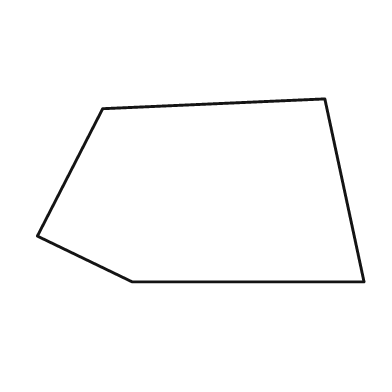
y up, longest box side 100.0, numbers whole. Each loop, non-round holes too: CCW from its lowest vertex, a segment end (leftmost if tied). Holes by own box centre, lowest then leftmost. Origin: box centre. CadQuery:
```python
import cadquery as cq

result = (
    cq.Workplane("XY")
    .moveTo(-21.0, -28.0)
    .lineTo(50.0, -28.0)
    .lineTo(38.0, 28.0)
    .lineTo(-30.0, 25.0)
    .lineTo(-50.0, -14.0)
    .close()
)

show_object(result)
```